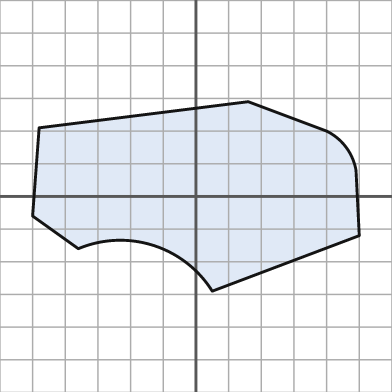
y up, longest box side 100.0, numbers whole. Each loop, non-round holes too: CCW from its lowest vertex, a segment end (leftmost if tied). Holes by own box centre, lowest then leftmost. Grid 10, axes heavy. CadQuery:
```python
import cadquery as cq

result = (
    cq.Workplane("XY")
    .moveTo(5.0, -29.0)
    .lineTo(50.0, -12.0)
    .lineTo(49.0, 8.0)
    .threePointArc((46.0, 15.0), (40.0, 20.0))
    .lineTo(16.0, 29.0)
    .lineTo(-48.0, 21.0)
    .lineTo(-50.0, -6.0)
    .lineTo(-36.0, -16.0)
    .threePointArc((-13.0, -15.0), (5.0, -29.0))
    .close()
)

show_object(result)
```